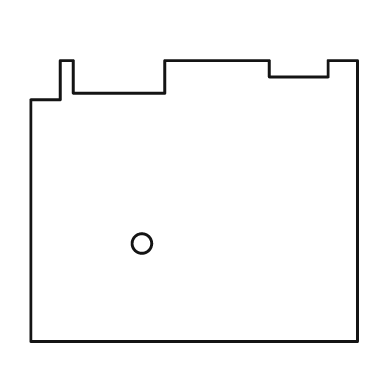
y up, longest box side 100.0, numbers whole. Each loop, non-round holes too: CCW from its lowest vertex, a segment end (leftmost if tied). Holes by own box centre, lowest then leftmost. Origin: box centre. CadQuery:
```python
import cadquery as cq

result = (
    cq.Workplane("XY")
    .moveTo(-50.0, -43.0)
    .lineTo(50.0, -43.0)
    .lineTo(50.0, 43.0)
    .lineTo(41.0, 43.0)
    .lineTo(41.0, 38.0)
    .lineTo(23.0, 38.0)
    .lineTo(23.0, 43.0)
    .lineTo(-9.0, 43.0)
    .lineTo(-9.0, 33.0)
    .lineTo(-37.0, 33.0)
    .lineTo(-37.0, 43.0)
    .lineTo(-41.0, 43.0)
    .lineTo(-41.0, 31.0)
    .lineTo(-50.0, 31.0)
    .close()
    .moveTo(-16.0, -13.0)
    .circle(3.0)
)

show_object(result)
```